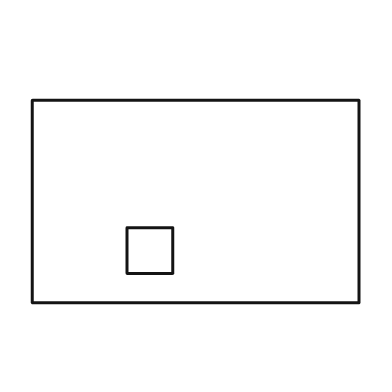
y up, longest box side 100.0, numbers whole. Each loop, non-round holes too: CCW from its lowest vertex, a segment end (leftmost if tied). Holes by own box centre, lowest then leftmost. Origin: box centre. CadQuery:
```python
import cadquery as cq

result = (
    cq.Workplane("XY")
    .moveTo(-50.0, -31.0)
    .lineTo(50.0, -31.0)
    .lineTo(50.0, 31.0)
    .lineTo(-50.0, 31.0)
    .close()
    .moveTo(-21.0, -22.0)
    .lineTo(-7.0, -22.0)
    .lineTo(-7.0, -8.0)
    .lineTo(-21.0, -8.0)
    .close()
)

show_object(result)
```